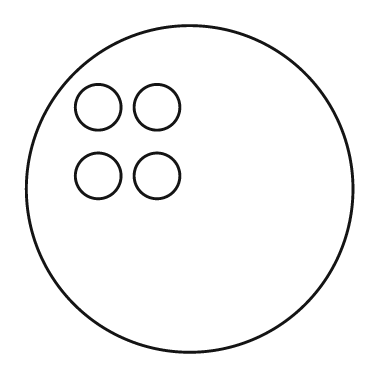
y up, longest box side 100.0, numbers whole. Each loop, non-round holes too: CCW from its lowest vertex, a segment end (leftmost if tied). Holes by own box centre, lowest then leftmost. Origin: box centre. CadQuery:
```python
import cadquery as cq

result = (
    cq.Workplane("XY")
    .moveTo(0.0, 0.0)
    .circle(50.0)
    .moveTo(-28.0, 4.0)
    .circle(7.0)
    .moveTo(-10.0, 4.0)
    .circle(7.0)
    .moveTo(-28.0, 25.0)
    .circle(7.0)
    .moveTo(-10.0, 25.0)
    .circle(7.0)
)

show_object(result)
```